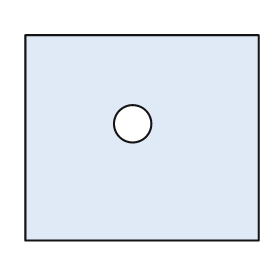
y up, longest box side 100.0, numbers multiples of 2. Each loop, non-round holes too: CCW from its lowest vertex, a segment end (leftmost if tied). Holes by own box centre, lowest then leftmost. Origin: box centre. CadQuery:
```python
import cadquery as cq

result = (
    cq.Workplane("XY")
    .moveTo(-50.0, -44.0)
    .lineTo(50.0, -44.0)
    .lineTo(50.0, 44.0)
    .lineTo(-50.0, 44.0)
    .close()
    .moveTo(-4.0, 6.0)
    .circle(8.0)
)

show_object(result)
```